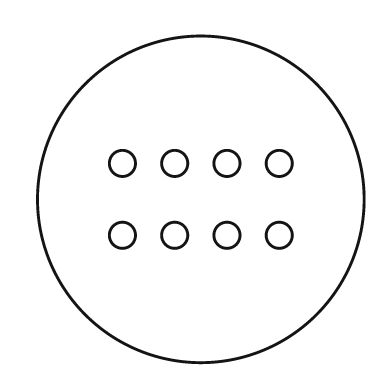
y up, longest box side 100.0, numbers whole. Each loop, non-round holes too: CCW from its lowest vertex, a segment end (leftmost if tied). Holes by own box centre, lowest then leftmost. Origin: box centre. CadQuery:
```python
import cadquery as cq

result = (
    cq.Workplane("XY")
    .moveTo(0.0, 0.0)
    .circle(50.0)
    .moveTo(-24.0, -11.0)
    .circle(4.0)
    .moveTo(-8.0, -11.0)
    .circle(4.0)
    .moveTo(8.0, -11.0)
    .circle(4.0)
    .moveTo(24.0, -11.0)
    .circle(4.0)
    .moveTo(-24.0, 11.0)
    .circle(4.0)
    .moveTo(-8.0, 11.0)
    .circle(4.0)
    .moveTo(8.0, 11.0)
    .circle(4.0)
    .moveTo(24.0, 11.0)
    .circle(4.0)
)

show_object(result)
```